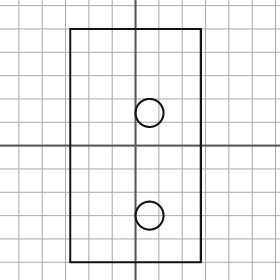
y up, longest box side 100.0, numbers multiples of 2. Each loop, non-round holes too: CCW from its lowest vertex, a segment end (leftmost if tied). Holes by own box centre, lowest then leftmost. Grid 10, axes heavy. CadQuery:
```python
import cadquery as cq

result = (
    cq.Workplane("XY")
    .moveTo(-28.0, -50.0)
    .lineTo(28.0, -50.0)
    .lineTo(28.0, 50.0)
    .lineTo(-28.0, 50.0)
    .close()
    .moveTo(6.0, -30.0)
    .circle(6.0)
    .moveTo(6.0, 14.0)
    .circle(6.0)
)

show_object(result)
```